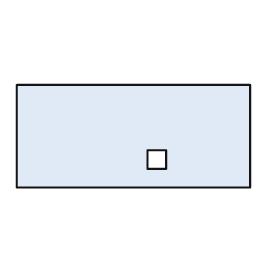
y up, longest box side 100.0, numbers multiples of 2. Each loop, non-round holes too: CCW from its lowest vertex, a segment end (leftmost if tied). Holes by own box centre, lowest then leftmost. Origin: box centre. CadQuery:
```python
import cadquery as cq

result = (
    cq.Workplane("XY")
    .moveTo(-50.0, -22.0)
    .lineTo(50.0, -22.0)
    .lineTo(50.0, 22.0)
    .lineTo(-50.0, 22.0)
    .close()
    .moveTo(6.0, -14.0)
    .lineTo(14.0, -14.0)
    .lineTo(14.0, -6.0)
    .lineTo(6.0, -6.0)
    .close()
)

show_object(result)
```